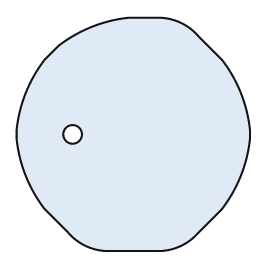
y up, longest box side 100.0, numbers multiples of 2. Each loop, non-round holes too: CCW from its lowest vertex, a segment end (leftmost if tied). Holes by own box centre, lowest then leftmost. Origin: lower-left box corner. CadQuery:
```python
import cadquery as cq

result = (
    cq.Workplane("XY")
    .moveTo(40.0, 0.0)
    .lineTo(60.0, 0.0)
    .threePointArc((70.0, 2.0), (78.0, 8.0))
    .lineTo(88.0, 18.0)
    .threePointArc((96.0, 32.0), (100.0, 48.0))
    .lineTo(100.0, 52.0)
    .threePointArc((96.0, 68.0), (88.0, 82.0))
    .lineTo(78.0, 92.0)
    .threePointArc((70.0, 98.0), (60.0, 100.0))
    .lineTo(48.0, 100.0)
    .threePointArc((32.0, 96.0), (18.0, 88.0))
    .lineTo(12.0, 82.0)
    .threePointArc((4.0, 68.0), (0.0, 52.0))
    .lineTo(0.0, 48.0)
    .threePointArc((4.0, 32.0), (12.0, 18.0))
    .lineTo(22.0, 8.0)
    .threePointArc((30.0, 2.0), (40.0, 0.0))
    .close()
    .moveTo(24.0, 50.0)
    .circle(4.0)
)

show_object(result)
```